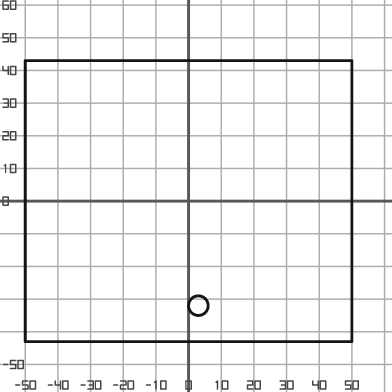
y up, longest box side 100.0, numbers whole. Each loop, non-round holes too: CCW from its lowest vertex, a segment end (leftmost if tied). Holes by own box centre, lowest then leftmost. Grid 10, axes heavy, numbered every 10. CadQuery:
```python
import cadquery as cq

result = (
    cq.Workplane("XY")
    .moveTo(-50.0, -43.0)
    .lineTo(50.0, -43.0)
    .lineTo(50.0, 43.0)
    .lineTo(-50.0, 43.0)
    .close()
    .moveTo(3.0, -32.0)
    .circle(3.0)
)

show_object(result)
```